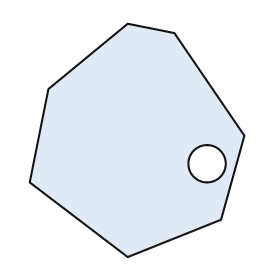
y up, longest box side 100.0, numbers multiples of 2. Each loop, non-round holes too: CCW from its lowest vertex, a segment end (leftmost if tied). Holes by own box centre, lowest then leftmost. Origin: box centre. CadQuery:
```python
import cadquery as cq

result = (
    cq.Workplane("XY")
    .moveTo(-4.0, -50.0)
    .lineTo(36.0, -34.0)
    .lineTo(46.0, 2.0)
    .lineTo(16.0, 46.0)
    .lineTo(-4.0, 50.0)
    .lineTo(-38.0, 22.0)
    .lineTo(-46.0, -18.0)
    .close()
    .moveTo(30.0, -10.0)
    .circle(8.0)
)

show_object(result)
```